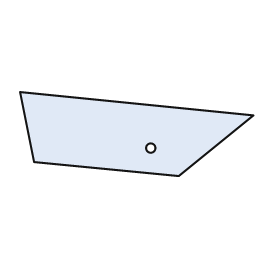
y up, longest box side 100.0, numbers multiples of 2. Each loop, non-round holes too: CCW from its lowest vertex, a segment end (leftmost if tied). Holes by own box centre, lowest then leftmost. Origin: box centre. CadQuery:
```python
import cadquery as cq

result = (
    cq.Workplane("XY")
    .moveTo(18.0, -18.0)
    .lineTo(50.0, 8.0)
    .lineTo(-50.0, 18.0)
    .lineTo(-44.0, -12.0)
    .close()
    .moveTo(6.0, -6.0)
    .circle(2.0)
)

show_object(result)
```